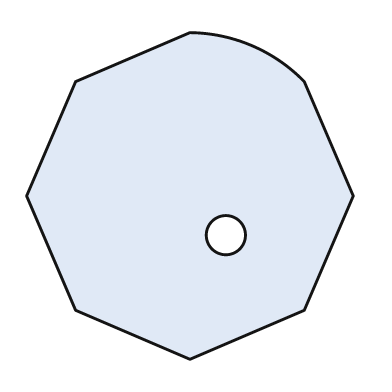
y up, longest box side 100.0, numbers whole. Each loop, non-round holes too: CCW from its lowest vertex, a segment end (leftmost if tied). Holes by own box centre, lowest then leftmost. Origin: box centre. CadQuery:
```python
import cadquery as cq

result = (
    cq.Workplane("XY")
    .moveTo(0.0, -50.0)
    .lineTo(35.0, -35.0)
    .lineTo(50.0, 0.0)
    .lineTo(35.0, 35.0)
    .threePointArc((19.0, 46.0), (0.0, 50.0))
    .lineTo(-35.0, 35.0)
    .lineTo(-50.0, 0.0)
    .lineTo(-35.0, -35.0)
    .close()
    .moveTo(11.0, -12.0)
    .circle(6.0)
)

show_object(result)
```